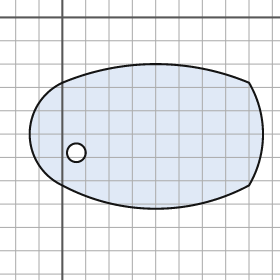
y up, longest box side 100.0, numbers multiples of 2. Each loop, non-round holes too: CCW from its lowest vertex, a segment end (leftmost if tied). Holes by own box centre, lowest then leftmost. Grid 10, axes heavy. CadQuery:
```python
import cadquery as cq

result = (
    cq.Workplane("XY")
    .moveTo(0.0, -72.0)
    .threePointArc((40.0, -82.0), (80.0, -72.0))
    .threePointArc((86.0, -50.0), (80.0, -28.0))
    .threePointArc((40.0, -20.0), (0.0, -28.0))
    .threePointArc((-14.0, -50.0), (0.0, -72.0))
    .close()
    .moveTo(6.0, -58.0)
    .circle(4.0)
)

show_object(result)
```